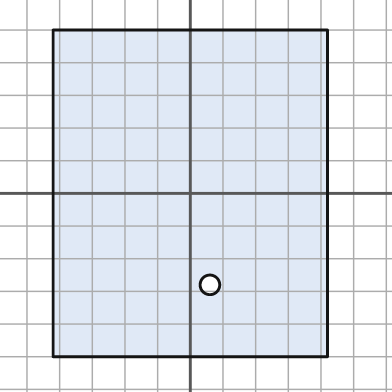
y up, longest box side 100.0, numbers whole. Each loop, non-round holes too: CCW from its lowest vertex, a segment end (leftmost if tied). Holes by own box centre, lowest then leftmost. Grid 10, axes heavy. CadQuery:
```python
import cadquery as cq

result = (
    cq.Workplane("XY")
    .moveTo(-42.0, -50.0)
    .lineTo(42.0, -50.0)
    .lineTo(42.0, 50.0)
    .lineTo(-42.0, 50.0)
    .close()
    .moveTo(6.0, -28.0)
    .circle(3.0)
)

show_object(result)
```